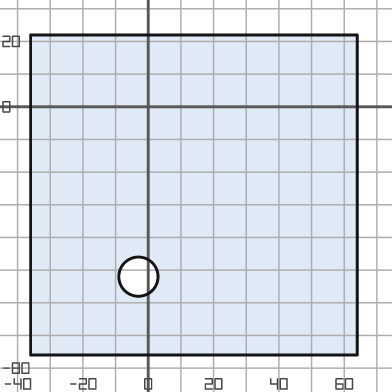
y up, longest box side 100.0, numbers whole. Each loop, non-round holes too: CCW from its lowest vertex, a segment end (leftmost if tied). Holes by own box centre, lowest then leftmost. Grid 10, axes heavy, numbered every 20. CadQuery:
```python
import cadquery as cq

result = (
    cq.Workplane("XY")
    .moveTo(-36.0, -76.0)
    .lineTo(64.0, -76.0)
    .lineTo(64.0, 22.0)
    .lineTo(-36.0, 22.0)
    .close()
    .moveTo(-3.0, -52.0)
    .circle(6.0)
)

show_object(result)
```